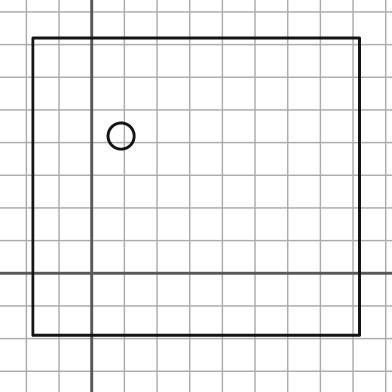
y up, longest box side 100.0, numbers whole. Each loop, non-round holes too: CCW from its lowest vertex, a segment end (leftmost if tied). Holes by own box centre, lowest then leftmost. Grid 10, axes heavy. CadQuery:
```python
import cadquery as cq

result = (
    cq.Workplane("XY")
    .moveTo(-18.0, -19.0)
    .lineTo(82.0, -19.0)
    .lineTo(82.0, 72.0)
    .lineTo(-18.0, 72.0)
    .close()
    .moveTo(9.0, 42.0)
    .circle(4.0)
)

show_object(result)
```